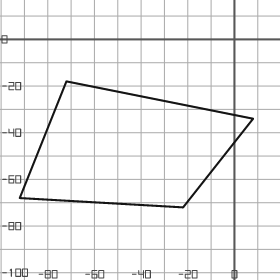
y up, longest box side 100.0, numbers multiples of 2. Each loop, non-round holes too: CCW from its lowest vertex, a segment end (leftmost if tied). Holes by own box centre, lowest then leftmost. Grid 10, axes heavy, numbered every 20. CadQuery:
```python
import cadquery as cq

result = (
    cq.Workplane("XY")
    .moveTo(-22.0, -72.0)
    .lineTo(8.0, -34.0)
    .lineTo(-72.0, -18.0)
    .lineTo(-92.0, -68.0)
    .close()
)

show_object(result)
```